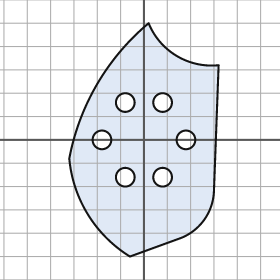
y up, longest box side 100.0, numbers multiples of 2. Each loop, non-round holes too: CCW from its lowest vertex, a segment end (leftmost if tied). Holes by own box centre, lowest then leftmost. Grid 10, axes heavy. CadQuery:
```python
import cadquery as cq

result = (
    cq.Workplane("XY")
    .moveTo(-6.0, -50.0)
    .lineTo(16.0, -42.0)
    .threePointArc((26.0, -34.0), (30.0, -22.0))
    .lineTo(32.0, 32.0)
    .threePointArc((14.0, 36.0), (2.0, 50.0))
    .threePointArc((-20.0, 24.0), (-32.0, -8.0))
    .threePointArc((-24.0, -32.0), (-6.0, -50.0))
    .close()
    .moveTo(-8.0, -16.0)
    .circle(4.0)
    .moveTo(8.0, -16.0)
    .circle(4.0)
    .moveTo(-18.0, 0.0)
    .circle(4.0)
    .moveTo(18.0, 0.0)
    .circle(4.0)
    .moveTo(-8.0, 16.0)
    .circle(4.0)
    .moveTo(8.0, 16.0)
    .circle(4.0)
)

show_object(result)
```